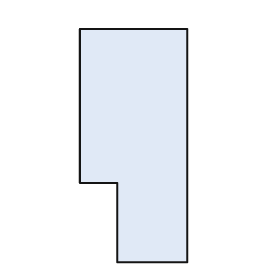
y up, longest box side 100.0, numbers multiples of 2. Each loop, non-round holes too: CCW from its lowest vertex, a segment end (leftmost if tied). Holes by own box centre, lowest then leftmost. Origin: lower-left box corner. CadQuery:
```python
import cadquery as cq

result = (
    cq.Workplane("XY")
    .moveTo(16.0, 0.0)
    .lineTo(46.0, 0.0)
    .lineTo(46.0, 100.0)
    .lineTo(0.0, 100.0)
    .lineTo(0.0, 34.0)
    .lineTo(16.0, 34.0)
    .close()
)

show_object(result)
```